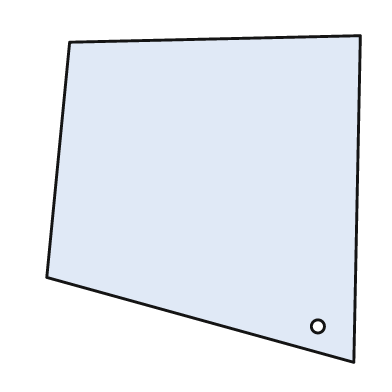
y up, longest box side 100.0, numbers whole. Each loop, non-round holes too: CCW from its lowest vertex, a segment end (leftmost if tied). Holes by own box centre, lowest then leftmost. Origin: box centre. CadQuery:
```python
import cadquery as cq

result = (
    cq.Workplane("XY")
    .moveTo(46.0, -50.0)
    .lineTo(48.0, 50.0)
    .lineTo(-41.0, 48.0)
    .lineTo(-48.0, -24.0)
    .close()
    .moveTo(35.0, -39.0)
    .circle(2.0)
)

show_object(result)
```